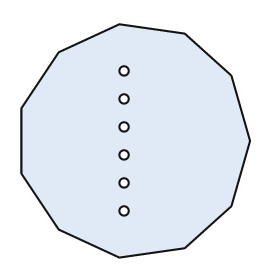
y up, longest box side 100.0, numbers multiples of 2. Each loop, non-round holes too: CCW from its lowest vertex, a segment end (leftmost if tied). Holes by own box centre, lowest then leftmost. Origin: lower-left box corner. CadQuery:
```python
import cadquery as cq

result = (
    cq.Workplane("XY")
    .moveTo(42.0, 0.0)
    .lineTo(70.0, 4.0)
    .lineTo(90.0, 22.0)
    .lineTo(98.0, 50.0)
    .lineTo(90.0, 78.0)
    .lineTo(70.0, 96.0)
    .lineTo(42.0, 100.0)
    .lineTo(16.0, 88.0)
    .lineTo(0.0, 64.0)
    .lineTo(0.0, 36.0)
    .lineTo(16.0, 12.0)
    .close()
    .moveTo(44.0, 20.0)
    .circle(2.0)
    .moveTo(44.0, 32.0)
    .circle(2.0)
    .moveTo(44.0, 44.0)
    .circle(2.0)
    .moveTo(44.0, 56.0)
    .circle(2.0)
    .moveTo(44.0, 68.0)
    .circle(2.0)
    .moveTo(44.0, 80.0)
    .circle(2.0)
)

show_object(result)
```